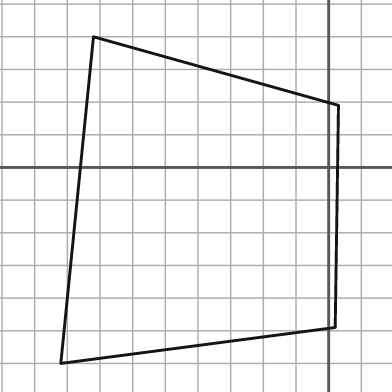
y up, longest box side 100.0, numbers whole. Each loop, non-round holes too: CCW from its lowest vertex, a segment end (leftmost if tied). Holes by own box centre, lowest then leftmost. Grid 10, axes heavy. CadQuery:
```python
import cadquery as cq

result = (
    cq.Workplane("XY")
    .moveTo(-82.0, -60.0)
    .lineTo(2.0, -49.0)
    .lineTo(3.0, 19.0)
    .lineTo(-72.0, 40.0)
    .close()
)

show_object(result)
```